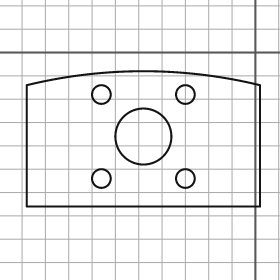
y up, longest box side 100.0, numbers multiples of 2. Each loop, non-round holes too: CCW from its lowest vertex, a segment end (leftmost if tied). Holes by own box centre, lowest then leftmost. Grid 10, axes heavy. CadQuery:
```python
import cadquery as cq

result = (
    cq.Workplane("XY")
    .moveTo(-98.0, -66.0)
    .lineTo(2.0, -66.0)
    .lineTo(2.0, -14.0)
    .threePointArc((-48.0, -8.0), (-98.0, -14.0))
    .close()
    .moveTo(-66.0, -54.0)
    .circle(4.0)
    .moveTo(-30.0, -54.0)
    .circle(4.0)
    .moveTo(-48.0, -36.0)
    .circle(12.0)
    .moveTo(-66.0, -18.0)
    .circle(4.0)
    .moveTo(-30.0, -18.0)
    .circle(4.0)
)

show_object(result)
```